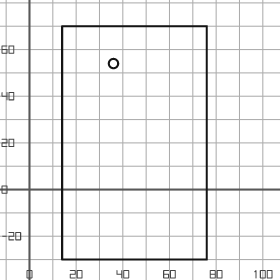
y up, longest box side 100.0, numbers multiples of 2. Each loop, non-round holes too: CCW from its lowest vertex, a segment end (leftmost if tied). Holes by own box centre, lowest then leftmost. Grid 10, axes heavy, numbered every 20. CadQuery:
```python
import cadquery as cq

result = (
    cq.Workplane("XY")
    .moveTo(14.0, -30.0)
    .lineTo(76.0, -30.0)
    .lineTo(76.0, 70.0)
    .lineTo(14.0, 70.0)
    .close()
    .moveTo(36.0, 54.0)
    .circle(2.0)
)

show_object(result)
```